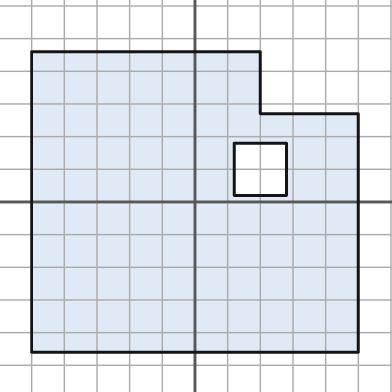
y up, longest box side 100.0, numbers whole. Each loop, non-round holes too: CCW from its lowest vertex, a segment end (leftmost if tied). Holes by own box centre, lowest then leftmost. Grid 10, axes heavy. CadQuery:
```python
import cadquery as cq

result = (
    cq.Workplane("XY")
    .moveTo(-50.0, -46.0)
    .lineTo(50.0, -46.0)
    .lineTo(50.0, 27.0)
    .lineTo(20.0, 27.0)
    .lineTo(20.0, 46.0)
    .lineTo(-50.0, 46.0)
    .close()
    .moveTo(12.0, 2.0)
    .lineTo(28.0, 2.0)
    .lineTo(28.0, 18.0)
    .lineTo(12.0, 18.0)
    .close()
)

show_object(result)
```